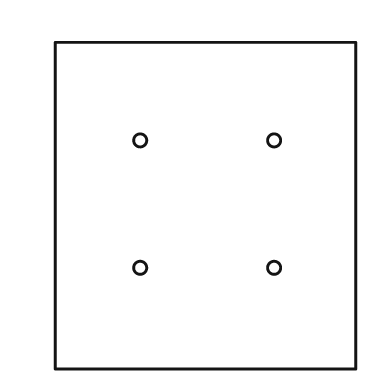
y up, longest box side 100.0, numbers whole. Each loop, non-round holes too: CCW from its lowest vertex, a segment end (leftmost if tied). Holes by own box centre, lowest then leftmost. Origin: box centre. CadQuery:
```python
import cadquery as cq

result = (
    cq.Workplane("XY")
    .moveTo(-46.0, -50.0)
    .lineTo(46.0, -50.0)
    .lineTo(46.0, 50.0)
    .lineTo(-46.0, 50.0)
    .close()
    .moveTo(-20.0, -19.0)
    .circle(2.0)
    .moveTo(21.0, -19.0)
    .circle(2.0)
    .moveTo(-20.0, 20.0)
    .circle(2.0)
    .moveTo(21.0, 20.0)
    .circle(2.0)
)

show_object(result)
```